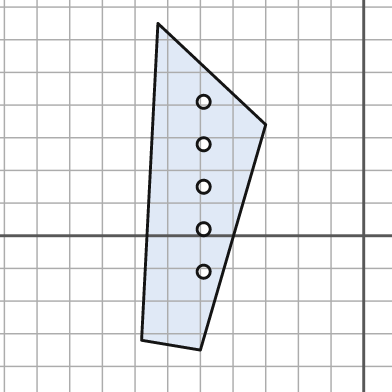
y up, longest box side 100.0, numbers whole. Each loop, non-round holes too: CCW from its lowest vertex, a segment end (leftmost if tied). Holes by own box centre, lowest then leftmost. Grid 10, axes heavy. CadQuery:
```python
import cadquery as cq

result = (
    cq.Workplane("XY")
    .moveTo(-50.0, -35.0)
    .lineTo(-30.0, 34.0)
    .lineTo(-63.0, 65.0)
    .lineTo(-68.0, -32.0)
    .close()
    .moveTo(-49.0, -11.0)
    .circle(2.0)
    .moveTo(-49.0, 2.0)
    .circle(2.0)
    .moveTo(-49.0, 15.0)
    .circle(2.0)
    .moveTo(-49.0, 28.0)
    .circle(2.0)
    .moveTo(-49.0, 41.0)
    .circle(2.0)
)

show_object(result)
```